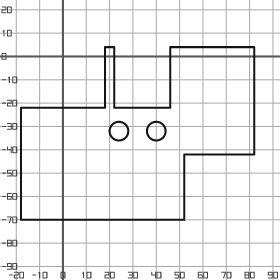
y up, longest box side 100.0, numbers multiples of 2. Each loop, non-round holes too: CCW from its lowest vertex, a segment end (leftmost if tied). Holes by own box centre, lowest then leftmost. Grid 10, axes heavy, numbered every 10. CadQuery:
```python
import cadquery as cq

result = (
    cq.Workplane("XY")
    .moveTo(-18.0, -70.0)
    .lineTo(52.0, -70.0)
    .lineTo(52.0, -42.0)
    .lineTo(82.0, -42.0)
    .lineTo(82.0, 4.0)
    .lineTo(46.0, 4.0)
    .lineTo(46.0, -22.0)
    .lineTo(22.0, -22.0)
    .lineTo(22.0, 4.0)
    .lineTo(18.0, 4.0)
    .lineTo(18.0, -22.0)
    .lineTo(-18.0, -22.0)
    .close()
    .moveTo(24.0, -32.0)
    .circle(4.0)
    .moveTo(40.0, -32.0)
    .circle(4.0)
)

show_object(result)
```